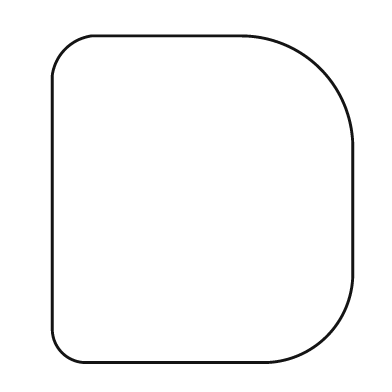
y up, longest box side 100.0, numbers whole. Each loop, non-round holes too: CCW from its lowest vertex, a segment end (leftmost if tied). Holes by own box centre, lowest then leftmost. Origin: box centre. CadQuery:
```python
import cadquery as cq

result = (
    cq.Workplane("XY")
    .moveTo(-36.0, -50.0)
    .lineTo(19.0, -50.0)
    .threePointArc((38.0, -42.0), (46.0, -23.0))
    .lineTo(46.0, 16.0)
    .threePointArc((36.0, 40.0), (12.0, 50.0))
    .lineTo(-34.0, 50.0)
    .threePointArc((-42.0, 46.0), (-46.0, 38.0))
    .lineTo(-46.0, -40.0)
    .threePointArc((-43.0, -47.0), (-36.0, -50.0))
    .close()
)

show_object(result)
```